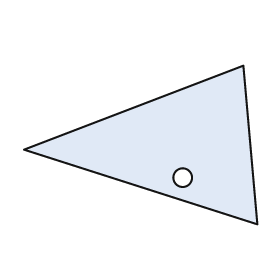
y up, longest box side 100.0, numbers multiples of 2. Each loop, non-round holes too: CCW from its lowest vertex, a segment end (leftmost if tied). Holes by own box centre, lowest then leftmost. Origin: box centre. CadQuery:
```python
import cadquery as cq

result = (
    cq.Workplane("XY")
    .moveTo(50.0, -34.0)
    .lineTo(44.0, 34.0)
    .lineTo(-50.0, -2.0)
    .close()
    .moveTo(18.0, -14.0)
    .circle(4.0)
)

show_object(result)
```